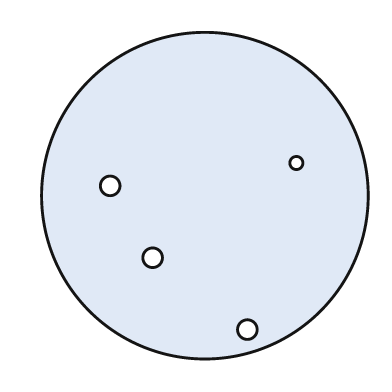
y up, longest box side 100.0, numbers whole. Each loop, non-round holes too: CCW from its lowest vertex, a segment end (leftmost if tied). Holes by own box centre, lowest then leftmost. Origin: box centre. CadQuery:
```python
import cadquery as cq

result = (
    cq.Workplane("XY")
    .moveTo(0.0, 0.0)
    .circle(50.0)
    .moveTo(13.0, -41.0)
    .circle(3.0)
    .moveTo(-16.0, -19.0)
    .circle(3.0)
    .moveTo(-29.0, 3.0)
    .circle(3.0)
    .moveTo(28.0, 10.0)
    .circle(2.0)
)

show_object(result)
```